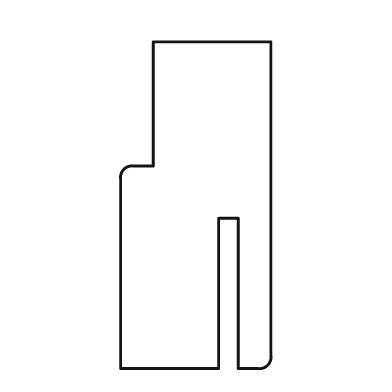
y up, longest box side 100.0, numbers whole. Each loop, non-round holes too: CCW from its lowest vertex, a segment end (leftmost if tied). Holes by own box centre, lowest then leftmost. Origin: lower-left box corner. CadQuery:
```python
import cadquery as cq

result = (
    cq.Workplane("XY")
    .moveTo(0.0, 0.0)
    .lineTo(30.0, 0.0)
    .lineTo(30.0, 46.0)
    .lineTo(36.0, 46.0)
    .lineTo(36.0, 0.0)
    .lineTo(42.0, 0.0)
    .threePointArc((45.0, 1.0), (46.0, 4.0))
    .lineTo(46.0, 100.0)
    .lineTo(10.0, 100.0)
    .lineTo(10.0, 62.0)
    .lineTo(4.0, 62.0)
    .threePointArc((1.0, 61.0), (0.0, 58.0))
    .close()
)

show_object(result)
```